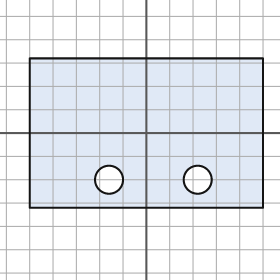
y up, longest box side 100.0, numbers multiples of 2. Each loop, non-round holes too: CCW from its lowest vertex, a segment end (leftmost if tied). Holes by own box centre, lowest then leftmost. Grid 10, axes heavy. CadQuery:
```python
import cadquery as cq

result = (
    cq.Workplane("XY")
    .moveTo(-50.0, -32.0)
    .lineTo(50.0, -32.0)
    .lineTo(50.0, 32.0)
    .lineTo(-50.0, 32.0)
    .close()
    .moveTo(-16.0, -20.0)
    .circle(6.0)
    .moveTo(22.0, -20.0)
    .circle(6.0)
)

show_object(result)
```